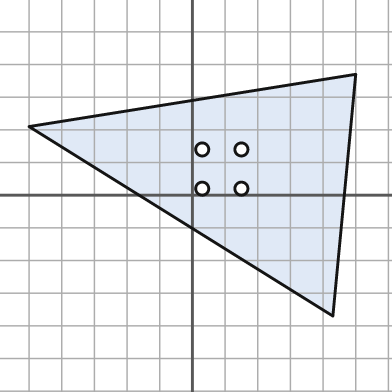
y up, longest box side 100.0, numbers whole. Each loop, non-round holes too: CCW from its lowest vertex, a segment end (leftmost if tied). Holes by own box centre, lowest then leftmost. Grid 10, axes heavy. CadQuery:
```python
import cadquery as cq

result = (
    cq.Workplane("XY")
    .moveTo(43.0, -37.0)
    .lineTo(50.0, 37.0)
    .lineTo(-50.0, 21.0)
    .close()
    .moveTo(3.0, 2.0)
    .circle(2.0)
    .moveTo(15.0, 2.0)
    .circle(2.0)
    .moveTo(3.0, 14.0)
    .circle(2.0)
    .moveTo(15.0, 14.0)
    .circle(2.0)
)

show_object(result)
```